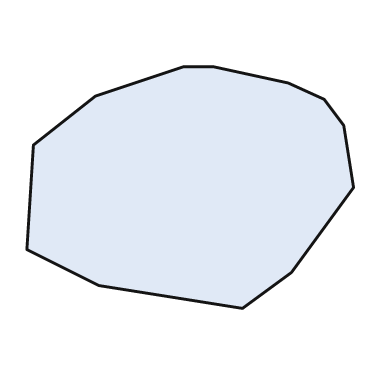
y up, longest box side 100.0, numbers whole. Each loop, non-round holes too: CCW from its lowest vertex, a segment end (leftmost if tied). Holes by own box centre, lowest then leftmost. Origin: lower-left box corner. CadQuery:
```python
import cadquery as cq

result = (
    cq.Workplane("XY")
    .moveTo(66.0, 0.0)
    .lineTo(81.0, 11.0)
    .lineTo(100.0, 37.0)
    .lineTo(97.0, 56.0)
    .lineTo(91.0, 64.0)
    .lineTo(80.0, 69.0)
    .lineTo(57.0, 74.0)
    .lineTo(48.0, 74.0)
    .lineTo(21.0, 65.0)
    .lineTo(2.0, 50.0)
    .lineTo(0.0, 18.0)
    .lineTo(22.0, 7.0)
    .close()
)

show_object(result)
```